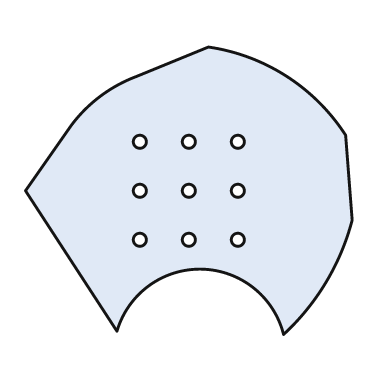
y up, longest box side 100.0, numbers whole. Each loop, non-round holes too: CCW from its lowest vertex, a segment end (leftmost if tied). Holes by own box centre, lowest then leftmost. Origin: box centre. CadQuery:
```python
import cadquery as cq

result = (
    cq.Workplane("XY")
    .moveTo(29.0, -44.0)
    .threePointArc((42.0, -28.0), (50.0, -9.0))
    .lineTo(48.0, 17.0)
    .threePointArc((30.0, 35.0), (6.0, 44.0))
    .lineTo(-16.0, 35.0)
    .threePointArc((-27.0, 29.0), (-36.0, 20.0))
    .lineTo(-50.0, 0.0)
    .lineTo(-22.0, -43.0)
    .threePointArc((4.0, -24.0), (29.0, -44.0))
    .close()
    .moveTo(-15.0, -15.0)
    .circle(2.0)
    .moveTo(0.0, -15.0)
    .circle(2.0)
    .moveTo(15.0, -15.0)
    .circle(2.0)
    .moveTo(-15.0, 0.0)
    .circle(2.0)
    .moveTo(0.0, 0.0)
    .circle(2.0)
    .moveTo(15.0, 0.0)
    .circle(2.0)
    .moveTo(-15.0, 15.0)
    .circle(2.0)
    .moveTo(0.0, 15.0)
    .circle(2.0)
    .moveTo(15.0, 15.0)
    .circle(2.0)
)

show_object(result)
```